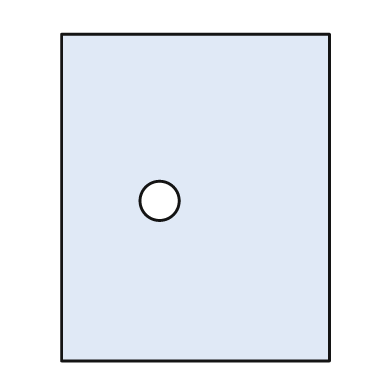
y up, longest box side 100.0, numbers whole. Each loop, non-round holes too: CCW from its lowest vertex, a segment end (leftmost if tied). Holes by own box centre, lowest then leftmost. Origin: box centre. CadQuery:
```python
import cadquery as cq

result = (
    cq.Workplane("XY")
    .moveTo(-41.0, -50.0)
    .lineTo(41.0, -50.0)
    .lineTo(41.0, 50.0)
    .lineTo(-41.0, 50.0)
    .close()
    .moveTo(-11.0, -1.0)
    .circle(6.0)
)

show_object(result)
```